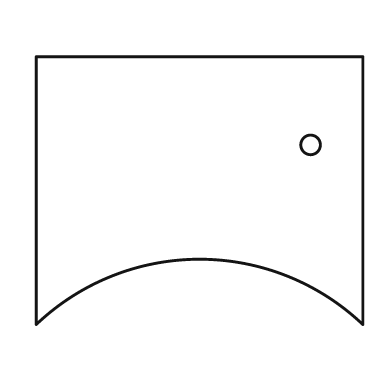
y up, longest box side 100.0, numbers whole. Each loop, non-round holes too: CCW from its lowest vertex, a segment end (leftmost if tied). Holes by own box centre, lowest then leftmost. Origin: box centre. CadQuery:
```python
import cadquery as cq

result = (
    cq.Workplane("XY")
    .moveTo(-50.0, -41.0)
    .threePointArc((0.0, -21.0), (50.0, -41.0))
    .lineTo(50.0, 41.0)
    .lineTo(-50.0, 41.0)
    .close()
    .moveTo(34.0, 14.0)
    .circle(3.0)
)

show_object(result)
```